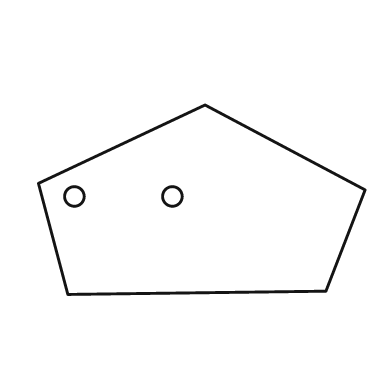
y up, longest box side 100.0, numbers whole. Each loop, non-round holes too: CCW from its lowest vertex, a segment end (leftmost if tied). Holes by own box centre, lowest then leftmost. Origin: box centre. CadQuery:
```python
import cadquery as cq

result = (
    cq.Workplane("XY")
    .moveTo(-41.0, -29.0)
    .lineTo(38.0, -28.0)
    .lineTo(50.0, 3.0)
    .lineTo(1.0, 29.0)
    .lineTo(-50.0, 5.0)
    .close()
    .moveTo(-39.0, 1.0)
    .circle(3.0)
    .moveTo(-9.0, 1.0)
    .circle(3.0)
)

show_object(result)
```